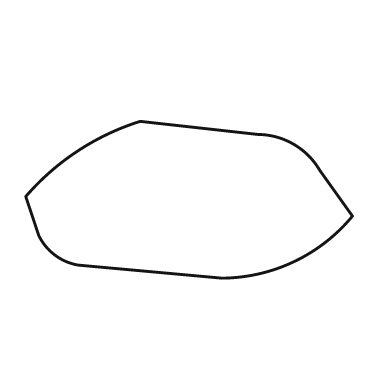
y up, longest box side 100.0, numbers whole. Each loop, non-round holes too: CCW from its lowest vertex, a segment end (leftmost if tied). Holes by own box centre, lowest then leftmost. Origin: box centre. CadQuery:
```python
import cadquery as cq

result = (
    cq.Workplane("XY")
    .moveTo(10.0, -24.0)
    .threePointArc((32.0, -19.0), (50.0, -5.0))
    .lineTo(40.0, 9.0)
    .threePointArc((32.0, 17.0), (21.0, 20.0))
    .lineTo(-15.0, 24.0)
    .threePointArc((-34.0, 15.0), (-50.0, 1.0))
    .lineTo(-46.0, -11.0)
    .threePointArc((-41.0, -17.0), (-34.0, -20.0))
    .close()
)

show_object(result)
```